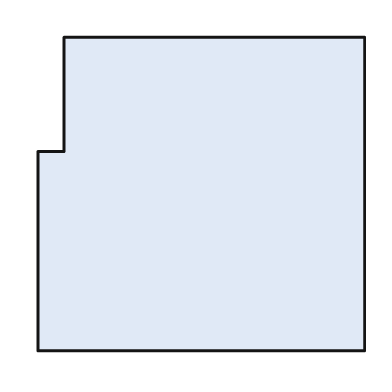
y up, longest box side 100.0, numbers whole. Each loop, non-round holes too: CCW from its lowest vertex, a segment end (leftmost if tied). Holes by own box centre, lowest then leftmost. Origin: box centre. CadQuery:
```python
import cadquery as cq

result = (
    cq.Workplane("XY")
    .moveTo(-50.0, -48.0)
    .lineTo(50.0, -48.0)
    .lineTo(50.0, 48.0)
    .lineTo(-42.0, 48.0)
    .lineTo(-42.0, 13.0)
    .lineTo(-50.0, 13.0)
    .close()
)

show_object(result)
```